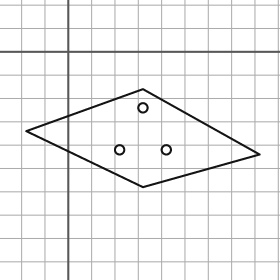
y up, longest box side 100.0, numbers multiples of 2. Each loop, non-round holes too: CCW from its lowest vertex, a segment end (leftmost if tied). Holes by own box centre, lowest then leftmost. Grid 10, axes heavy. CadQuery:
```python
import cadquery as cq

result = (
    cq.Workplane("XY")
    .moveTo(32.0, -58.0)
    .lineTo(82.0, -44.0)
    .lineTo(32.0, -16.0)
    .lineTo(-18.0, -34.0)
    .close()
    .moveTo(22.0, -42.0)
    .circle(2.0)
    .moveTo(42.0, -42.0)
    .circle(2.0)
    .moveTo(32.0, -24.0)
    .circle(2.0)
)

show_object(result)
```